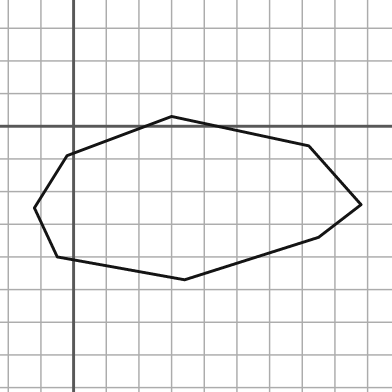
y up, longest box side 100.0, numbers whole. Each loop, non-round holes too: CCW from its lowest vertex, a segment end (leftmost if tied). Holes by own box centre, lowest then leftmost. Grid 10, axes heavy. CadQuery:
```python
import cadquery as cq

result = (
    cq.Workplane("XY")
    .moveTo(34.0, -47.0)
    .lineTo(75.0, -34.0)
    .lineTo(88.0, -24.0)
    .lineTo(72.0, -6.0)
    .lineTo(30.0, 3.0)
    .lineTo(-2.0, -9.0)
    .lineTo(-12.0, -25.0)
    .lineTo(-5.0, -40.0)
    .close()
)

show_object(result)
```